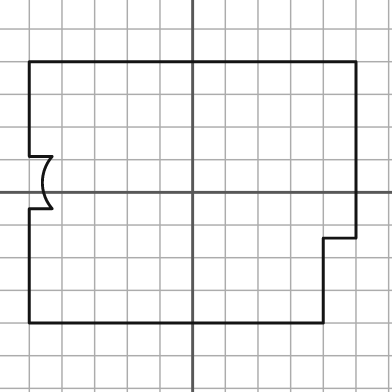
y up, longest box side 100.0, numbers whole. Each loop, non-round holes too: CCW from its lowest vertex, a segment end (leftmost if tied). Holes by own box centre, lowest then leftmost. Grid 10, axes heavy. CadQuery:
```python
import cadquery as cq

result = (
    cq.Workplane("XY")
    .moveTo(-50.0, -40.0)
    .lineTo(40.0, -40.0)
    .lineTo(40.0, -14.0)
    .lineTo(50.0, -14.0)
    .lineTo(50.0, 40.0)
    .lineTo(-50.0, 40.0)
    .lineTo(-50.0, 11.0)
    .lineTo(-43.0, 11.0)
    .threePointArc((-46.0, 3.0), (-43.0, -5.0))
    .lineTo(-50.0, -5.0)
    .close()
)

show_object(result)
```